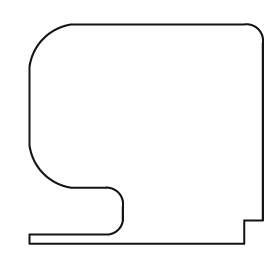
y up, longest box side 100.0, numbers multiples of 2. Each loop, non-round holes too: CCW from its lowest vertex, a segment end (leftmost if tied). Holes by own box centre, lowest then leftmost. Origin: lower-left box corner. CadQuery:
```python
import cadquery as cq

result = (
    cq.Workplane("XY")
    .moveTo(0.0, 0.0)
    .lineTo(92.0, 0.0)
    .lineTo(92.0, 10.0)
    .lineTo(100.0, 10.0)
    .lineTo(100.0, 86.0)
    .threePointArc((98.0, 92.0), (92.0, 94.0))
    .lineTo(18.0, 94.0)
    .threePointArc((6.0, 88.0), (0.0, 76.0))
    .lineTo(0.0, 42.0)
    .threePointArc((6.0, 30.0), (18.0, 24.0))
    .lineTo(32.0, 24.0)
    .threePointArc((38.0, 22.0), (40.0, 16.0))
    .lineTo(40.0, 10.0)
    .threePointArc((38.0, 6.0), (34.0, 4.0))
    .lineTo(0.0, 4.0)
    .close()
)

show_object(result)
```